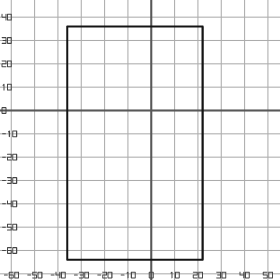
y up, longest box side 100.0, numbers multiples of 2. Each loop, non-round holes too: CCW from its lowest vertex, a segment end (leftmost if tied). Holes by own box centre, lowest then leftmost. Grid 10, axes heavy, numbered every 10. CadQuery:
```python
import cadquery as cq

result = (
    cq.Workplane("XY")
    .moveTo(-36.0, -64.0)
    .lineTo(22.0, -64.0)
    .lineTo(22.0, 36.0)
    .lineTo(-36.0, 36.0)
    .close()
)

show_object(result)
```